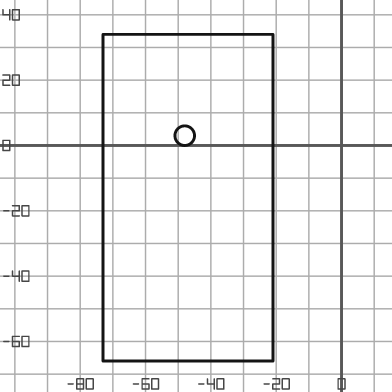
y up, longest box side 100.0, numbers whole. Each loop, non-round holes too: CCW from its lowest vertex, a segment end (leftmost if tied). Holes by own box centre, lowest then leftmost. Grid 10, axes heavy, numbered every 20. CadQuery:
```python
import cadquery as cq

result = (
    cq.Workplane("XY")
    .moveTo(-73.0, -66.0)
    .lineTo(-21.0, -66.0)
    .lineTo(-21.0, 34.0)
    .lineTo(-73.0, 34.0)
    .close()
    .moveTo(-48.0, 3.0)
    .circle(3.0)
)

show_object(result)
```